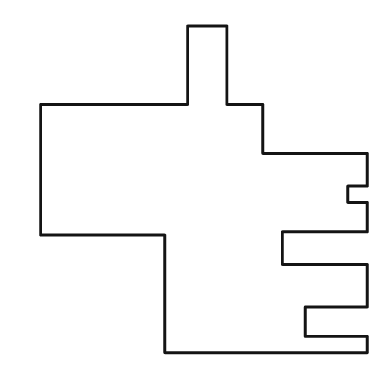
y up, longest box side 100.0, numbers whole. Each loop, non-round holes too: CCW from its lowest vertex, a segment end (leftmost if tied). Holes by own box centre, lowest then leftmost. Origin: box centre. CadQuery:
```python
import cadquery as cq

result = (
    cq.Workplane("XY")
    .moveTo(-12.0, -50.0)
    .lineTo(50.0, -50.0)
    .lineTo(50.0, -45.0)
    .lineTo(31.0, -45.0)
    .lineTo(31.0, -36.0)
    .lineTo(50.0, -36.0)
    .lineTo(50.0, -23.0)
    .lineTo(24.0, -23.0)
    .lineTo(24.0, -13.0)
    .lineTo(50.0, -13.0)
    .lineTo(50.0, -4.0)
    .lineTo(44.0, -4.0)
    .lineTo(44.0, 1.0)
    .lineTo(50.0, 1.0)
    .lineTo(50.0, 11.0)
    .lineTo(18.0, 11.0)
    .lineTo(18.0, 26.0)
    .lineTo(7.0, 26.0)
    .lineTo(7.0, 50.0)
    .lineTo(-5.0, 50.0)
    .lineTo(-5.0, 26.0)
    .lineTo(-50.0, 26.0)
    .lineTo(-50.0, -14.0)
    .lineTo(-12.0, -14.0)
    .close()
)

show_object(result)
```